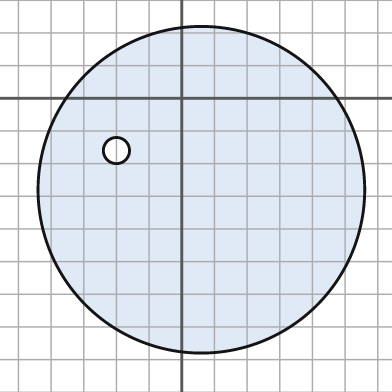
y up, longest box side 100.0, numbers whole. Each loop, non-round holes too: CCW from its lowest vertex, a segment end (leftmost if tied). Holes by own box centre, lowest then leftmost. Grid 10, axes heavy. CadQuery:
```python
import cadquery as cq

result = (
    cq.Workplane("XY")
    .moveTo(6.0, -28.0)
    .circle(50.0)
    .moveTo(-20.0, -16.0)
    .circle(4.0)
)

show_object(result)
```